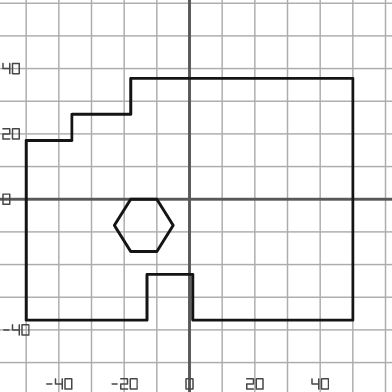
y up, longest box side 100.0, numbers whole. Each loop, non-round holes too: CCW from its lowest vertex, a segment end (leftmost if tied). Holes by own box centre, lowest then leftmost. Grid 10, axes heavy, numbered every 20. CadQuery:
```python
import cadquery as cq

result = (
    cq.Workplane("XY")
    .moveTo(-50.0, -37.0)
    .lineTo(-13.0, -37.0)
    .lineTo(-13.0, -23.0)
    .lineTo(1.0, -23.0)
    .lineTo(1.0, -37.0)
    .lineTo(50.0, -37.0)
    .lineTo(50.0, 37.0)
    .lineTo(-18.0, 37.0)
    .lineTo(-18.0, 26.0)
    .lineTo(-36.0, 26.0)
    .lineTo(-36.0, 18.0)
    .lineTo(-50.0, 18.0)
    .close()
    .moveTo(-18.0, -16.0)
    .lineTo(-10.0, -16.0)
    .lineTo(-5.0, -8.0)
    .lineTo(-10.0, 0.0)
    .lineTo(-18.0, 0.0)
    .lineTo(-23.0, -8.0)
    .close()
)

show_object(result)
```